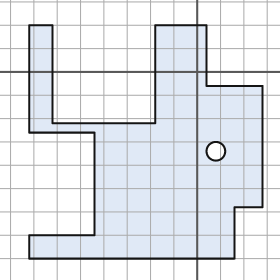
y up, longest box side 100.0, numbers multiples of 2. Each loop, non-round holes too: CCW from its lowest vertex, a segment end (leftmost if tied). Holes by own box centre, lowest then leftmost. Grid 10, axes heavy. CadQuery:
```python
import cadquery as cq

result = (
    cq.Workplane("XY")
    .moveTo(-72.0, -80.0)
    .lineTo(16.0, -80.0)
    .lineTo(16.0, -58.0)
    .lineTo(28.0, -58.0)
    .lineTo(28.0, -6.0)
    .lineTo(4.0, -6.0)
    .lineTo(4.0, 20.0)
    .lineTo(-18.0, 20.0)
    .lineTo(-18.0, -22.0)
    .lineTo(-62.0, -22.0)
    .lineTo(-62.0, 20.0)
    .lineTo(-72.0, 20.0)
    .lineTo(-72.0, -26.0)
    .lineTo(-44.0, -26.0)
    .lineTo(-44.0, -70.0)
    .lineTo(-72.0, -70.0)
    .close()
    .moveTo(8.0, -34.0)
    .circle(4.0)
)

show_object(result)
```